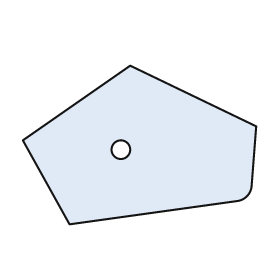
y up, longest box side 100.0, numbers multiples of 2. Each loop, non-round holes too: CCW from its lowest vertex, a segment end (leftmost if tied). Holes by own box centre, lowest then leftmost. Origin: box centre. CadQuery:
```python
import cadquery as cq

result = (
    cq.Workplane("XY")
    .moveTo(-30.0, -34.0)
    .lineTo(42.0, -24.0)
    .threePointArc((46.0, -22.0), (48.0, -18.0))
    .lineTo(50.0, 8.0)
    .lineTo(-4.0, 34.0)
    .lineTo(-50.0, 2.0)
    .close()
    .moveTo(-8.0, -2.0)
    .circle(4.0)
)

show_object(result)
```